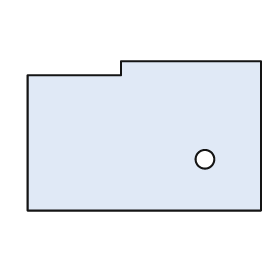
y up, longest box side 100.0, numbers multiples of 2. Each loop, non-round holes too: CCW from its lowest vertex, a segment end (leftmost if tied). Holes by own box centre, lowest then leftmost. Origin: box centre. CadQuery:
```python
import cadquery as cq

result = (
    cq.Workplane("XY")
    .moveTo(-50.0, -32.0)
    .lineTo(50.0, -32.0)
    .lineTo(50.0, 32.0)
    .lineTo(-10.0, 32.0)
    .lineTo(-10.0, 26.0)
    .lineTo(-50.0, 26.0)
    .close()
    .moveTo(26.0, -10.0)
    .circle(4.0)
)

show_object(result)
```